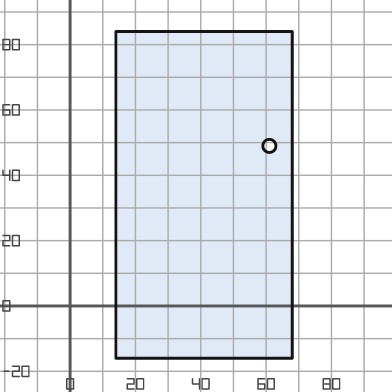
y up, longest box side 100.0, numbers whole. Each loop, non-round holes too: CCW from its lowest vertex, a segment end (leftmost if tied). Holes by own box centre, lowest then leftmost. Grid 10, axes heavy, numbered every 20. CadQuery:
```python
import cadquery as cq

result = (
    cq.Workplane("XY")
    .moveTo(14.0, -16.0)
    .lineTo(68.0, -16.0)
    .lineTo(68.0, 84.0)
    .lineTo(14.0, 84.0)
    .close()
    .moveTo(61.0, 49.0)
    .circle(2.0)
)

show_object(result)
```